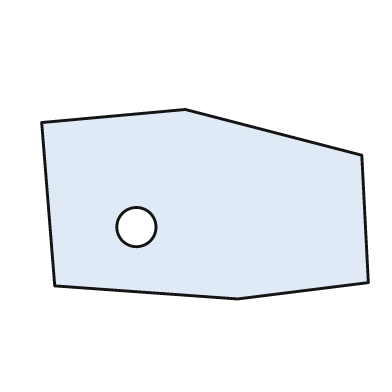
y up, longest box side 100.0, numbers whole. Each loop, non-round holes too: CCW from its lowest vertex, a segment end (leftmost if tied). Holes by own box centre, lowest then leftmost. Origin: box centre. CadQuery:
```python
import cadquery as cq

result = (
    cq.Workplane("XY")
    .moveTo(10.0, -29.0)
    .lineTo(50.0, -24.0)
    .lineTo(48.0, 15.0)
    .lineTo(-6.0, 29.0)
    .lineTo(-50.0, 25.0)
    .lineTo(-46.0, -25.0)
    .close()
    .moveTo(-21.0, -7.0)
    .circle(6.0)
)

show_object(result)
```